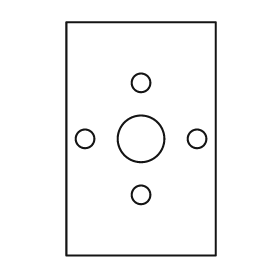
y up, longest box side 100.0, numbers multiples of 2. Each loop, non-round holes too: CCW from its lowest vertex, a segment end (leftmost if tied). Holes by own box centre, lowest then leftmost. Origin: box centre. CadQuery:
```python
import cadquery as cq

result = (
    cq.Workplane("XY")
    .moveTo(-32.0, -50.0)
    .lineTo(32.0, -50.0)
    .lineTo(32.0, 50.0)
    .lineTo(-32.0, 50.0)
    .close()
    .moveTo(0.0, -24.0)
    .circle(4.0)
    .moveTo(-24.0, 0.0)
    .circle(4.0)
    .moveTo(0.0, 0.0)
    .circle(10.0)
    .moveTo(24.0, 0.0)
    .circle(4.0)
    .moveTo(0.0, 24.0)
    .circle(4.0)
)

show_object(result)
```